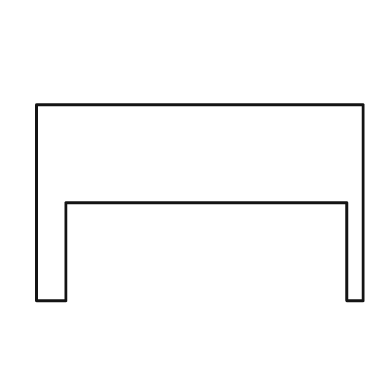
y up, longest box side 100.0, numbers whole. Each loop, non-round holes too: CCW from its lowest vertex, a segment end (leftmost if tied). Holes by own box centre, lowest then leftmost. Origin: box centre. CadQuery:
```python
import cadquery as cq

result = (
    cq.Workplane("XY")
    .moveTo(-50.0, -30.0)
    .lineTo(-41.0, -30.0)
    .lineTo(-41.0, 0.0)
    .lineTo(45.0, 0.0)
    .lineTo(45.0, -30.0)
    .lineTo(50.0, -30.0)
    .lineTo(50.0, 30.0)
    .lineTo(-50.0, 30.0)
    .close()
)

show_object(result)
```